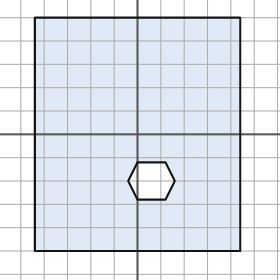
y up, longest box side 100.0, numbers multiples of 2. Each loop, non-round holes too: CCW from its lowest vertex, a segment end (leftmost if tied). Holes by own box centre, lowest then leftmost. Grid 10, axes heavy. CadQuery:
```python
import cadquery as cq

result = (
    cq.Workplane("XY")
    .moveTo(-44.0, -50.0)
    .lineTo(44.0, -50.0)
    .lineTo(44.0, 50.0)
    .lineTo(-44.0, 50.0)
    .close()
    .moveTo(0.0, -28.0)
    .lineTo(12.0, -28.0)
    .lineTo(16.0, -20.0)
    .lineTo(12.0, -12.0)
    .lineTo(0.0, -12.0)
    .lineTo(-4.0, -20.0)
    .close()
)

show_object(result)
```